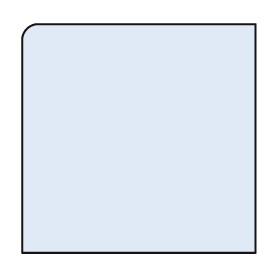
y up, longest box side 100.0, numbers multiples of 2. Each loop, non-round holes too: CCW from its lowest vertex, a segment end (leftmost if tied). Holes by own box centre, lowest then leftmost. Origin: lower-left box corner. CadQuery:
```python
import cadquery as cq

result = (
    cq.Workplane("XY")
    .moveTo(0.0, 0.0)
    .lineTo(100.0, 0.0)
    .lineTo(100.0, 98.0)
    .lineTo(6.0, 98.0)
    .threePointArc((2.0, 96.0), (0.0, 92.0))
    .close()
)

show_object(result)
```